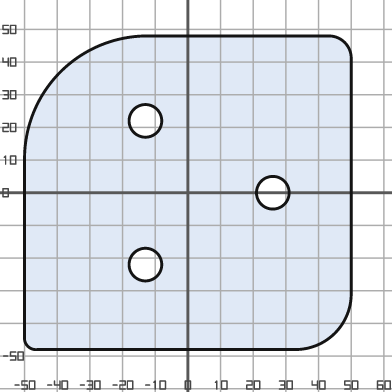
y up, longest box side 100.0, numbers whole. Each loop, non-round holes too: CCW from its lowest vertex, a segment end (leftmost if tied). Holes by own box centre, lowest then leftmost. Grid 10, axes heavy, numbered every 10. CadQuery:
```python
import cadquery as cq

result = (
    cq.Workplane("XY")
    .moveTo(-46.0, -48.0)
    .lineTo(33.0, -48.0)
    .threePointArc((45.0, -43.0), (50.0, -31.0))
    .lineTo(50.0, 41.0)
    .threePointArc((48.0, 46.0), (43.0, 48.0))
    .lineTo(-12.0, 48.0)
    .threePointArc((-39.0, 37.0), (-50.0, 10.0))
    .lineTo(-50.0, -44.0)
    .threePointArc((-49.0, -47.0), (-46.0, -48.0))
    .close()
    .moveTo(-13.0, -22.0)
    .circle(5.0)
    .moveTo(26.0, 0.0)
    .circle(5.0)
    .moveTo(-13.0, 22.0)
    .circle(5.0)
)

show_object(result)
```